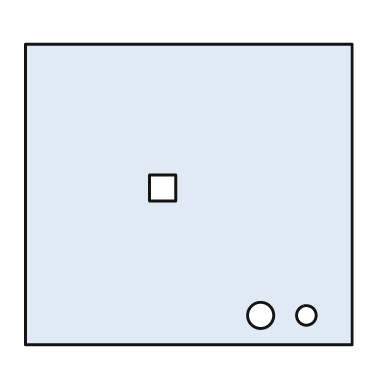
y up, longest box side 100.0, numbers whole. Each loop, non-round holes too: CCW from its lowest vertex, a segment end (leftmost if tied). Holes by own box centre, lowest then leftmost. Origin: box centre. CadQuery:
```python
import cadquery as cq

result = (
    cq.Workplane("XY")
    .moveTo(-50.0, -46.0)
    .lineTo(50.0, -46.0)
    .lineTo(50.0, 46.0)
    .lineTo(-50.0, 46.0)
    .close()
    .moveTo(22.0, -37.0)
    .circle(4.0)
    .moveTo(36.0, -37.0)
    .circle(3.0)
    .moveTo(-12.0, -2.0)
    .lineTo(-4.0, -2.0)
    .lineTo(-4.0, 6.0)
    .lineTo(-12.0, 6.0)
    .close()
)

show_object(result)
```